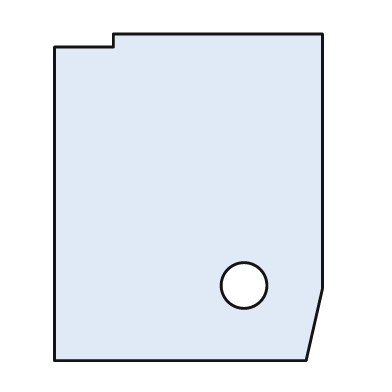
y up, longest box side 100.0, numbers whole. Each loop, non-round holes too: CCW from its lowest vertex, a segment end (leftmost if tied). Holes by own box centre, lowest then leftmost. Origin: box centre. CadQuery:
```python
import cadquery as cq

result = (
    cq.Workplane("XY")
    .moveTo(-41.0, -50.0)
    .lineTo(36.0, -50.0)
    .lineTo(41.0, -28.0)
    .lineTo(41.0, 50.0)
    .lineTo(-23.0, 50.0)
    .lineTo(-23.0, 46.0)
    .lineTo(-41.0, 46.0)
    .close()
    .moveTo(17.0, -27.0)
    .circle(7.0)
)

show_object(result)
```